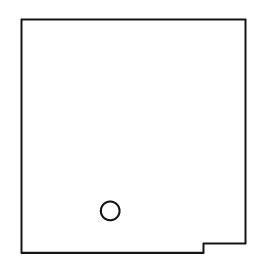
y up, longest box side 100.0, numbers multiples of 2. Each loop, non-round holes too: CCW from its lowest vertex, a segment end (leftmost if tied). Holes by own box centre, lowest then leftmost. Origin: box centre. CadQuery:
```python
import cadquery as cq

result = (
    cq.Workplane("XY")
    .moveTo(-48.0, -50.0)
    .lineTo(30.0, -50.0)
    .lineTo(30.0, -46.0)
    .lineTo(48.0, -46.0)
    .lineTo(48.0, 50.0)
    .lineTo(-48.0, 50.0)
    .close()
    .moveTo(-10.0, -32.0)
    .circle(4.0)
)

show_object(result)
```